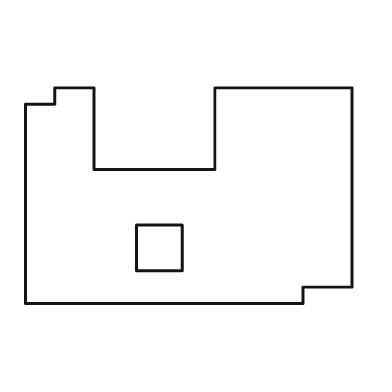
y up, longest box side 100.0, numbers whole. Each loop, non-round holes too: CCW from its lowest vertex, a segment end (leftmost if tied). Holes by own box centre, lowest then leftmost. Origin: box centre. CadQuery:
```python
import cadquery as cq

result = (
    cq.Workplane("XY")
    .moveTo(-50.0, -33.0)
    .lineTo(35.0, -33.0)
    .lineTo(35.0, -28.0)
    .lineTo(50.0, -28.0)
    .lineTo(50.0, 33.0)
    .lineTo(8.0, 33.0)
    .lineTo(8.0, 8.0)
    .lineTo(-29.0, 8.0)
    .lineTo(-29.0, 33.0)
    .lineTo(-41.0, 33.0)
    .lineTo(-41.0, 28.0)
    .lineTo(-50.0, 28.0)
    .close()
    .moveTo(-16.0, -23.0)
    .lineTo(-2.0, -23.0)
    .lineTo(-2.0, -9.0)
    .lineTo(-16.0, -9.0)
    .close()
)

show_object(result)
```